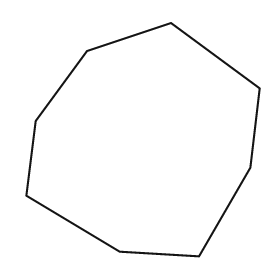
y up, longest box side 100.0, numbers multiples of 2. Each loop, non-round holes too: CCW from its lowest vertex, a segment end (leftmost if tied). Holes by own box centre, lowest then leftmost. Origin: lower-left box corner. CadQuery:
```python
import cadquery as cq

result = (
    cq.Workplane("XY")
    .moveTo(74.0, 0.0)
    .lineTo(96.0, 38.0)
    .lineTo(100.0, 72.0)
    .lineTo(62.0, 100.0)
    .lineTo(26.0, 88.0)
    .lineTo(4.0, 58.0)
    .lineTo(0.0, 26.0)
    .lineTo(40.0, 2.0)
    .close()
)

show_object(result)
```